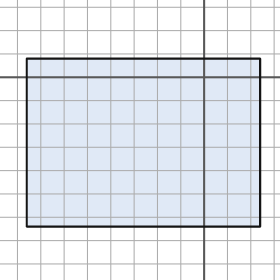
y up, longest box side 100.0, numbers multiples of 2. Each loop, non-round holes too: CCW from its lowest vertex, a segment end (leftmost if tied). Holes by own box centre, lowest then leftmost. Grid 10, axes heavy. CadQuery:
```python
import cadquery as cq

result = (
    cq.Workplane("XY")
    .moveTo(-76.0, -64.0)
    .lineTo(24.0, -64.0)
    .lineTo(24.0, 8.0)
    .lineTo(-76.0, 8.0)
    .close()
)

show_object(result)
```